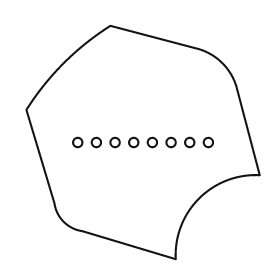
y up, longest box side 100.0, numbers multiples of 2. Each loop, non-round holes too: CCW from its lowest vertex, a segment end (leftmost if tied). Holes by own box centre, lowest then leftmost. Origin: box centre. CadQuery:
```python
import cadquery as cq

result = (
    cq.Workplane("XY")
    .moveTo(14.0, -50.0)
    .threePointArc((24.0, -24.0), (50.0, -14.0))
    .lineTo(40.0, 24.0)
    .threePointArc((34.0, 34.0), (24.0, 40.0))
    .lineTo(-14.0, 50.0)
    .threePointArc((-34.0, 34.0), (-50.0, 14.0))
    .lineTo(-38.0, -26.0)
    .threePointArc((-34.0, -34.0), (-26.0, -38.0))
    .close()
    .moveTo(-28.0, 0.0)
    .circle(2.0)
    .moveTo(-20.0, 0.0)
    .circle(2.0)
    .moveTo(-12.0, 0.0)
    .circle(2.0)
    .moveTo(-4.0, 0.0)
    .circle(2.0)
    .moveTo(4.0, 0.0)
    .circle(2.0)
    .moveTo(12.0, 0.0)
    .circle(2.0)
    .moveTo(20.0, 0.0)
    .circle(2.0)
    .moveTo(28.0, 0.0)
    .circle(2.0)
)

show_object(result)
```